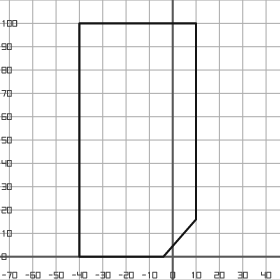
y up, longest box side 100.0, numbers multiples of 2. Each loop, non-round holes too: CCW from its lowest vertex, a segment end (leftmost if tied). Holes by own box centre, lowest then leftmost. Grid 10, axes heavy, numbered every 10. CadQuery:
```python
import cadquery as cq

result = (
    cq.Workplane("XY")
    .moveTo(-40.0, 0.0)
    .lineTo(-4.0, 0.0)
    .lineTo(10.0, 16.0)
    .lineTo(10.0, 100.0)
    .lineTo(-40.0, 100.0)
    .close()
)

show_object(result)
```